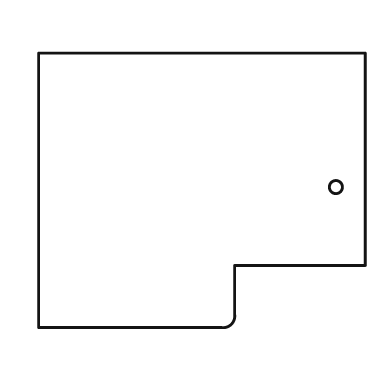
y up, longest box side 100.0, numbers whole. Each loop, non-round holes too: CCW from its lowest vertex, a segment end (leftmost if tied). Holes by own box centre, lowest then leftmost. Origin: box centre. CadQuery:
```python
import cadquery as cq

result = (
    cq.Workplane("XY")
    .moveTo(-50.0, -42.0)
    .lineTo(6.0, -42.0)
    .threePointArc((9.0, -41.0), (10.0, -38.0))
    .lineTo(10.0, -23.0)
    .lineTo(50.0, -23.0)
    .lineTo(50.0, 42.0)
    .lineTo(-50.0, 42.0)
    .close()
    .moveTo(41.0, 1.0)
    .circle(2.0)
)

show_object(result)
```